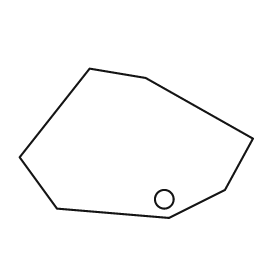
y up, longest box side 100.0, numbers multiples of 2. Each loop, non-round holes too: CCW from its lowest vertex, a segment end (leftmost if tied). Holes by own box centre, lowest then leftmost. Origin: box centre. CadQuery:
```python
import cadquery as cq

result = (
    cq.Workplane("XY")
    .moveTo(14.0, -32.0)
    .lineTo(38.0, -20.0)
    .lineTo(50.0, 2.0)
    .lineTo(4.0, 28.0)
    .lineTo(-20.0, 32.0)
    .lineTo(-50.0, -6.0)
    .lineTo(-34.0, -28.0)
    .close()
    .moveTo(12.0, -24.0)
    .circle(4.0)
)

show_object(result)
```